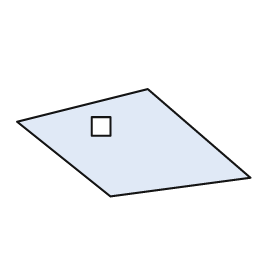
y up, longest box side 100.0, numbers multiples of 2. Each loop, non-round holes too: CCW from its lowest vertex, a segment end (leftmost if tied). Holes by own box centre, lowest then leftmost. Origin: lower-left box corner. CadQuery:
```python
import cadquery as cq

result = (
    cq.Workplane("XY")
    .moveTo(40.0, 0.0)
    .lineTo(100.0, 8.0)
    .lineTo(56.0, 46.0)
    .lineTo(0.0, 32.0)
    .close()
    .moveTo(32.0, 26.0)
    .lineTo(40.0, 26.0)
    .lineTo(40.0, 34.0)
    .lineTo(32.0, 34.0)
    .close()
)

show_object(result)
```